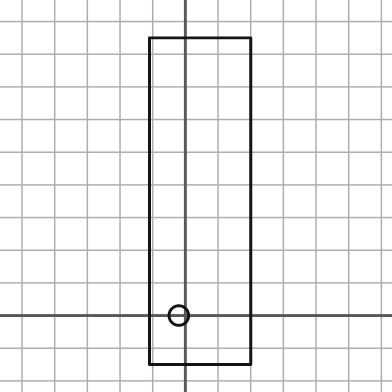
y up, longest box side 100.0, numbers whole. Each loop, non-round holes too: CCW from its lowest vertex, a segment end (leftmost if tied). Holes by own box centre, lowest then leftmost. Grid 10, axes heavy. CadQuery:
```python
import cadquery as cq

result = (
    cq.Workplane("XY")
    .moveTo(-11.0, -15.0)
    .lineTo(20.0, -15.0)
    .lineTo(20.0, 85.0)
    .lineTo(-11.0, 85.0)
    .close()
    .moveTo(-2.0, 0.0)
    .circle(3.0)
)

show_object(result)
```